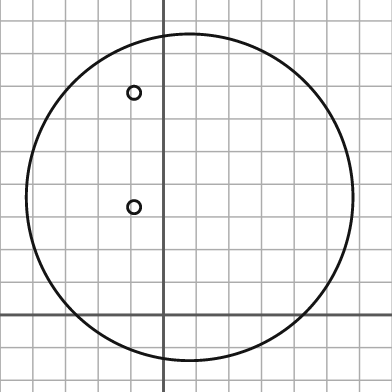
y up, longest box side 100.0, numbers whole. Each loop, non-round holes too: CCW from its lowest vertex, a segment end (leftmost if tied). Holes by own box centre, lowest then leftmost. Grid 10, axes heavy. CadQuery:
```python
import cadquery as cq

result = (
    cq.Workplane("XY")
    .moveTo(8.0, 36.0)
    .circle(50.0)
    .moveTo(-9.0, 33.0)
    .circle(2.0)
    .moveTo(-9.0, 68.0)
    .circle(2.0)
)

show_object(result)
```